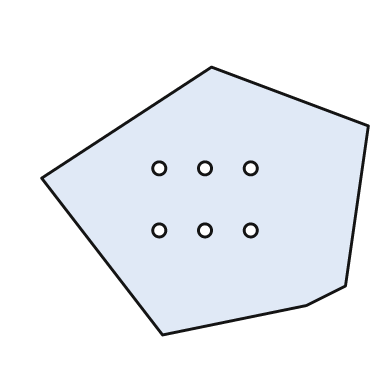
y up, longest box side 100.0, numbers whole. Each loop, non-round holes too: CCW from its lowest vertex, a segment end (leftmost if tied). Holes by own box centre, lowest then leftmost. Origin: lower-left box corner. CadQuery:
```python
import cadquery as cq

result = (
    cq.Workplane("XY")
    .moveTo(37.0, 0.0)
    .lineTo(81.0, 9.0)
    .lineTo(93.0, 15.0)
    .lineTo(100.0, 64.0)
    .lineTo(52.0, 82.0)
    .lineTo(0.0, 48.0)
    .close()
    .moveTo(36.0, 32.0)
    .circle(2.0)
    .moveTo(50.0, 32.0)
    .circle(2.0)
    .moveTo(64.0, 32.0)
    .circle(2.0)
    .moveTo(36.0, 51.0)
    .circle(2.0)
    .moveTo(50.0, 51.0)
    .circle(2.0)
    .moveTo(64.0, 51.0)
    .circle(2.0)
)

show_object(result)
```